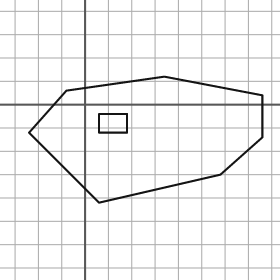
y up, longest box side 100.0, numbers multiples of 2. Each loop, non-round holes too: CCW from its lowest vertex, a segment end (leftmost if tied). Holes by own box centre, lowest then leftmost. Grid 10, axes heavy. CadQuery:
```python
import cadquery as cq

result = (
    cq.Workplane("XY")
    .moveTo(6.0, -42.0)
    .lineTo(58.0, -30.0)
    .lineTo(76.0, -14.0)
    .lineTo(76.0, 4.0)
    .lineTo(34.0, 12.0)
    .lineTo(-8.0, 6.0)
    .lineTo(-24.0, -12.0)
    .close()
    .moveTo(6.0, -12.0)
    .lineTo(18.0, -12.0)
    .lineTo(18.0, -4.0)
    .lineTo(6.0, -4.0)
    .close()
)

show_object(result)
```